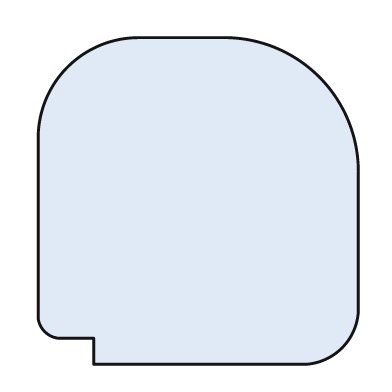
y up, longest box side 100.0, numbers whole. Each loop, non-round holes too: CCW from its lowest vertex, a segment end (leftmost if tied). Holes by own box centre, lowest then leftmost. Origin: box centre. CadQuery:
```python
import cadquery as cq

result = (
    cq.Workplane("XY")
    .moveTo(-32.0, -50.0)
    .lineTo(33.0, -50.0)
    .threePointArc((44.0, -45.0), (49.0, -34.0))
    .lineTo(49.0, 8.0)
    .threePointArc((37.0, 38.0), (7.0, 50.0))
    .lineTo(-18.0, 50.0)
    .threePointArc((-40.0, 41.0), (-49.0, 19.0))
    .lineTo(-49.0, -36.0)
    .threePointArc((-47.0, -40.0), (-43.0, -42.0))
    .lineTo(-32.0, -42.0)
    .close()
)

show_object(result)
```